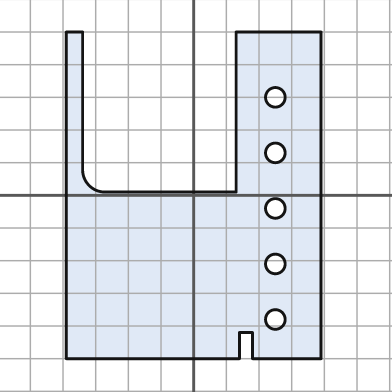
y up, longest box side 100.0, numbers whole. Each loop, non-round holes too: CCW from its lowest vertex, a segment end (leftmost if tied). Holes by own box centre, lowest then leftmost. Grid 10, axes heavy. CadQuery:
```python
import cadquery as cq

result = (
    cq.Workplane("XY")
    .moveTo(-39.0, -50.0)
    .lineTo(14.0, -50.0)
    .lineTo(14.0, -42.0)
    .lineTo(18.0, -42.0)
    .lineTo(18.0, -50.0)
    .lineTo(39.0, -50.0)
    .lineTo(39.0, 50.0)
    .lineTo(13.0, 50.0)
    .lineTo(13.0, 1.0)
    .lineTo(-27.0, 1.0)
    .threePointArc((-32.0, 3.0), (-34.0, 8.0))
    .lineTo(-34.0, 50.0)
    .lineTo(-39.0, 50.0)
    .close()
    .moveTo(25.0, -38.0)
    .circle(3.0)
    .moveTo(25.0, -21.0)
    .circle(3.0)
    .moveTo(25.0, -4.0)
    .circle(3.0)
    .moveTo(25.0, 13.0)
    .circle(3.0)
    .moveTo(25.0, 30.0)
    .circle(3.0)
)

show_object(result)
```